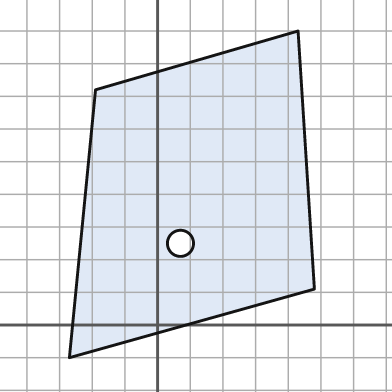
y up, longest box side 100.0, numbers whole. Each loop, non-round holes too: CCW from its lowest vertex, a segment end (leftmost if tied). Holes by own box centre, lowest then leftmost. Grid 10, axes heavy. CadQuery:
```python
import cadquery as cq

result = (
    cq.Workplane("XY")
    .moveTo(-27.0, -10.0)
    .lineTo(48.0, 11.0)
    .lineTo(43.0, 90.0)
    .lineTo(-19.0, 72.0)
    .close()
    .moveTo(7.0, 25.0)
    .circle(4.0)
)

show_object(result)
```